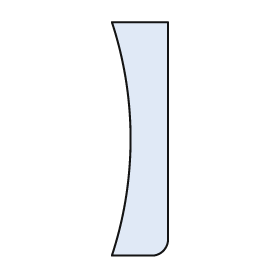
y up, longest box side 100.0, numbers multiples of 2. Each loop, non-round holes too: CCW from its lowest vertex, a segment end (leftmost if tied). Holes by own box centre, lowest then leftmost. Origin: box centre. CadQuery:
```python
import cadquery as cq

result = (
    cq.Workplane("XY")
    .moveTo(-12.0, -50.0)
    .lineTo(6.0, -50.0)
    .threePointArc((10.0, -48.0), (12.0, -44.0))
    .lineTo(12.0, 50.0)
    .lineTo(-12.0, 50.0)
    .threePointArc((-4.0, 0.0), (-12.0, -50.0))
    .close()
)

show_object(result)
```